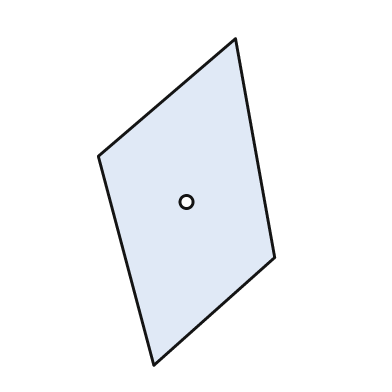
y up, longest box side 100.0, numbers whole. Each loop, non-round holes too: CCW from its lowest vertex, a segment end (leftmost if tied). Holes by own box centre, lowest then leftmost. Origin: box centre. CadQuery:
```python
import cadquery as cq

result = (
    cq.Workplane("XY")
    .moveTo(-10.0, -50.0)
    .lineTo(27.0, -17.0)
    .lineTo(15.0, 50.0)
    .lineTo(-27.0, 14.0)
    .close()
    .moveTo(0.0, 0.0)
    .circle(2.0)
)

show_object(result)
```